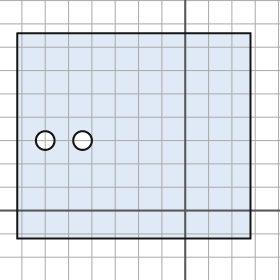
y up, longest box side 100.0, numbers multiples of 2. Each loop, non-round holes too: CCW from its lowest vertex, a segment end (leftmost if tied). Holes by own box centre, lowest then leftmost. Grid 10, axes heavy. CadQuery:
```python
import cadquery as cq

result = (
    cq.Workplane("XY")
    .moveTo(-72.0, -12.0)
    .lineTo(28.0, -12.0)
    .lineTo(28.0, 76.0)
    .lineTo(-72.0, 76.0)
    .close()
    .moveTo(-60.0, 30.0)
    .circle(4.0)
    .moveTo(-44.0, 30.0)
    .circle(4.0)
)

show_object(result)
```